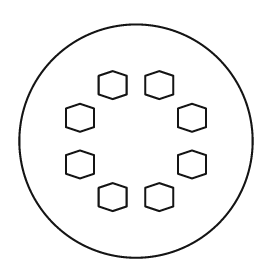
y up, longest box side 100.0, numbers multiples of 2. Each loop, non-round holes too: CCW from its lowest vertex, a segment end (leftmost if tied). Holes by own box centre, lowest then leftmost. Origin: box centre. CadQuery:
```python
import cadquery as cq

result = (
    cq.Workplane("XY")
    .moveTo(0.0, 0.0)
    .circle(50.0)
    .moveTo(-10.0, -30.0)
    .lineTo(-4.0, -28.0)
    .lineTo(-4.0, -20.0)
    .lineTo(-10.0, -18.0)
    .lineTo(-16.0, -20.0)
    .lineTo(-16.0, -28.0)
    .close()
    .moveTo(10.0, -30.0)
    .lineTo(16.0, -28.0)
    .lineTo(16.0, -20.0)
    .lineTo(10.0, -18.0)
    .lineTo(4.0, -20.0)
    .lineTo(4.0, -28.0)
    .close()
    .moveTo(-24.0, -16.0)
    .lineTo(-18.0, -14.0)
    .lineTo(-18.0, -6.0)
    .lineTo(-24.0, -4.0)
    .lineTo(-30.0, -6.0)
    .lineTo(-30.0, -14.0)
    .close()
    .moveTo(24.0, -16.0)
    .lineTo(30.0, -14.0)
    .lineTo(30.0, -6.0)
    .lineTo(24.0, -4.0)
    .lineTo(18.0, -6.0)
    .lineTo(18.0, -14.0)
    .close()
    .moveTo(-24.0, 4.0)
    .lineTo(-18.0, 6.0)
    .lineTo(-18.0, 14.0)
    .lineTo(-24.0, 16.0)
    .lineTo(-30.0, 14.0)
    .lineTo(-30.0, 6.0)
    .close()
    .moveTo(24.0, 4.0)
    .lineTo(30.0, 6.0)
    .lineTo(30.0, 14.0)
    .lineTo(24.0, 16.0)
    .lineTo(18.0, 14.0)
    .lineTo(18.0, 6.0)
    .close()
    .moveTo(-10.0, 18.0)
    .lineTo(-4.0, 20.0)
    .lineTo(-4.0, 28.0)
    .lineTo(-10.0, 30.0)
    .lineTo(-16.0, 28.0)
    .lineTo(-16.0, 20.0)
    .close()
    .moveTo(10.0, 18.0)
    .lineTo(16.0, 20.0)
    .lineTo(16.0, 28.0)
    .lineTo(10.0, 30.0)
    .lineTo(4.0, 28.0)
    .lineTo(4.0, 20.0)
    .close()
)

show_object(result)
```